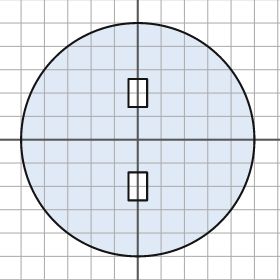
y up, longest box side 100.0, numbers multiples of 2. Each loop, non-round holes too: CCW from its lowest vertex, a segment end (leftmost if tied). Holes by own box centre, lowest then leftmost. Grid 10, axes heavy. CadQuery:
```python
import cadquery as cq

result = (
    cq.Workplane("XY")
    .moveTo(0.0, 0.0)
    .circle(50.0)
    .moveTo(-4.0, -26.0)
    .lineTo(4.0, -26.0)
    .lineTo(4.0, -14.0)
    .lineTo(-4.0, -14.0)
    .close()
    .moveTo(-4.0, 14.0)
    .lineTo(4.0, 14.0)
    .lineTo(4.0, 26.0)
    .lineTo(-4.0, 26.0)
    .close()
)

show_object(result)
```